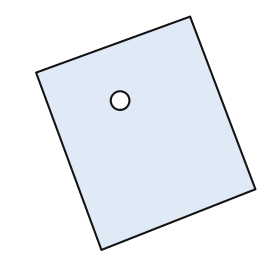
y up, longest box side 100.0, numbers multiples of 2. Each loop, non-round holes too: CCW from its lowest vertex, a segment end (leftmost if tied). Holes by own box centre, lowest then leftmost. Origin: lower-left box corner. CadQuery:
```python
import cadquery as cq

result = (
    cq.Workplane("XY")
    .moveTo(28.0, 0.0)
    .lineTo(94.0, 26.0)
    .lineTo(66.0, 100.0)
    .lineTo(0.0, 76.0)
    .close()
    .moveTo(36.0, 64.0)
    .circle(4.0)
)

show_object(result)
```